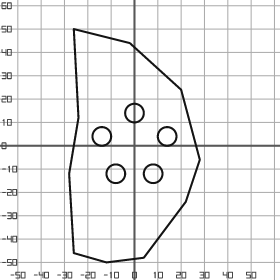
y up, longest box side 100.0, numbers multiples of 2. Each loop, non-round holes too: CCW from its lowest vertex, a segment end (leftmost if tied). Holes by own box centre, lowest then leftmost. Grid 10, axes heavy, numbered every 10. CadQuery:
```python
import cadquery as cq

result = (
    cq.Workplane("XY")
    .moveTo(-12.0, -50.0)
    .lineTo(4.0, -48.0)
    .lineTo(22.0, -24.0)
    .lineTo(28.0, -6.0)
    .lineTo(20.0, 24.0)
    .lineTo(-2.0, 44.0)
    .lineTo(-26.0, 50.0)
    .lineTo(-24.0, 12.0)
    .lineTo(-28.0, -12.0)
    .lineTo(-26.0, -46.0)
    .close()
    .moveTo(-8.0, -12.0)
    .circle(4.0)
    .moveTo(8.0, -12.0)
    .circle(4.0)
    .moveTo(-14.0, 4.0)
    .circle(4.0)
    .moveTo(14.0, 4.0)
    .circle(4.0)
    .moveTo(0.0, 14.0)
    .circle(4.0)
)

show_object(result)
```